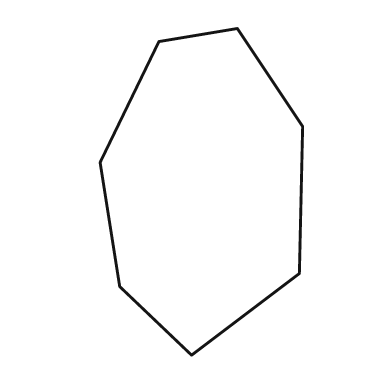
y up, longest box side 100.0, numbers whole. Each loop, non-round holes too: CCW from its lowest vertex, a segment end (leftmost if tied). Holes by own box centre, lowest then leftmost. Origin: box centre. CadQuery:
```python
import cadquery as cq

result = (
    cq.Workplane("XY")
    .moveTo(-3.0, -50.0)
    .lineTo(30.0, -25.0)
    .lineTo(31.0, 20.0)
    .lineTo(11.0, 50.0)
    .lineTo(-13.0, 46.0)
    .lineTo(-31.0, 9.0)
    .lineTo(-25.0, -29.0)
    .close()
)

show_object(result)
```